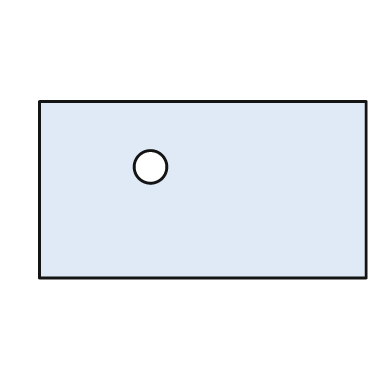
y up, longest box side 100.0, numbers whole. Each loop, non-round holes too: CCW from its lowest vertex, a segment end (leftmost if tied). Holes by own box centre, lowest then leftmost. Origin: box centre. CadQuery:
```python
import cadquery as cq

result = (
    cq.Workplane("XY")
    .moveTo(-50.0, -27.0)
    .lineTo(50.0, -27.0)
    .lineTo(50.0, 27.0)
    .lineTo(-50.0, 27.0)
    .close()
    .moveTo(-16.0, 7.0)
    .circle(5.0)
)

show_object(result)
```